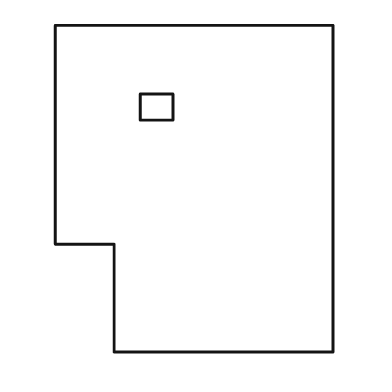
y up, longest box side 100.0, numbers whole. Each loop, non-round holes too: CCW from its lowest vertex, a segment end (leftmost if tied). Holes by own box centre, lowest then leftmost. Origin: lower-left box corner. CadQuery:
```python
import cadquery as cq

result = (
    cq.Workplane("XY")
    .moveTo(18.0, 0.0)
    .lineTo(85.0, 0.0)
    .lineTo(85.0, 100.0)
    .lineTo(0.0, 100.0)
    .lineTo(0.0, 33.0)
    .lineTo(18.0, 33.0)
    .close()
    .moveTo(26.0, 71.0)
    .lineTo(36.0, 71.0)
    .lineTo(36.0, 79.0)
    .lineTo(26.0, 79.0)
    .close()
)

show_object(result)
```